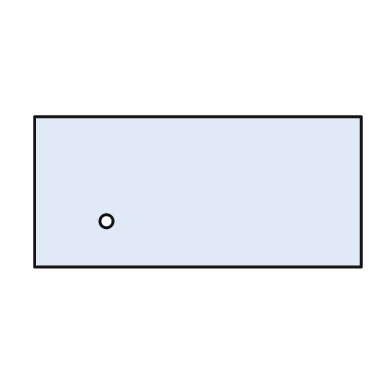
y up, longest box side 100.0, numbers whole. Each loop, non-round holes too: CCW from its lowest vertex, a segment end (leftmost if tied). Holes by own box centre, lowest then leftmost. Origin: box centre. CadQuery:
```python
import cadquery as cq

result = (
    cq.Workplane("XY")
    .moveTo(-50.0, -23.0)
    .lineTo(50.0, -23.0)
    .lineTo(50.0, 23.0)
    .lineTo(-50.0, 23.0)
    .close()
    .moveTo(-28.0, -9.0)
    .circle(2.0)
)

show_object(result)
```